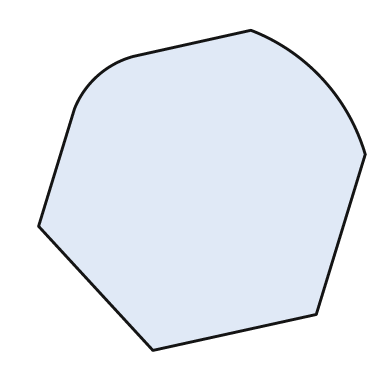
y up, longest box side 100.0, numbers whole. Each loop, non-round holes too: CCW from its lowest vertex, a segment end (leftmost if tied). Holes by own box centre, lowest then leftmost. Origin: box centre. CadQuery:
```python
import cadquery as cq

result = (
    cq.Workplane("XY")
    .moveTo(-15.0, -49.0)
    .lineTo(35.0, -38.0)
    .lineTo(50.0, 11.0)
    .threePointArc((37.0, 34.0), (15.0, 49.0))
    .lineTo(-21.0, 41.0)
    .threePointArc((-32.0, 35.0), (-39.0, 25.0))
    .lineTo(-50.0, -11.0)
    .close()
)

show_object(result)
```